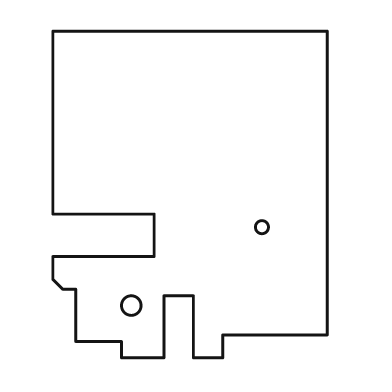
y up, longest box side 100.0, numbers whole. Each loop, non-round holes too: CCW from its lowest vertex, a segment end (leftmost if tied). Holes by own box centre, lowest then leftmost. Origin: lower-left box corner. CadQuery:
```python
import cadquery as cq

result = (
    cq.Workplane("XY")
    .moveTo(21.0, 0.0)
    .lineTo(34.0, 0.0)
    .lineTo(34.0, 19.0)
    .lineTo(43.0, 19.0)
    .lineTo(43.0, 0.0)
    .lineTo(52.0, 0.0)
    .lineTo(52.0, 7.0)
    .lineTo(84.0, 7.0)
    .lineTo(84.0, 100.0)
    .lineTo(0.0, 100.0)
    .lineTo(0.0, 44.0)
    .lineTo(31.0, 44.0)
    .lineTo(31.0, 31.0)
    .lineTo(0.0, 31.0)
    .lineTo(0.0, 24.0)
    .lineTo(3.0, 21.0)
    .lineTo(7.0, 21.0)
    .lineTo(7.0, 5.0)
    .lineTo(21.0, 5.0)
    .close()
    .moveTo(24.0, 16.0)
    .circle(3.0)
    .moveTo(64.0, 40.0)
    .circle(2.0)
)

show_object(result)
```